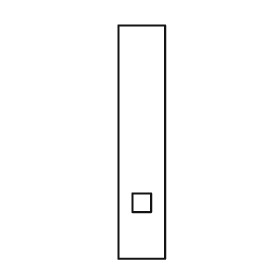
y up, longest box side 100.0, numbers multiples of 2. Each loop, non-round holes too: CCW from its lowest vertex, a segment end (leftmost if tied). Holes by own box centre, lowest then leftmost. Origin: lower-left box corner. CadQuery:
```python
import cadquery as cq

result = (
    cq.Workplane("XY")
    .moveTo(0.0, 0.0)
    .lineTo(20.0, 0.0)
    .lineTo(20.0, 100.0)
    .lineTo(0.0, 100.0)
    .close()
    .moveTo(6.0, 20.0)
    .lineTo(14.0, 20.0)
    .lineTo(14.0, 28.0)
    .lineTo(6.0, 28.0)
    .close()
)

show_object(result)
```